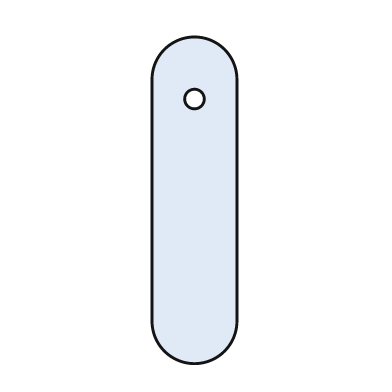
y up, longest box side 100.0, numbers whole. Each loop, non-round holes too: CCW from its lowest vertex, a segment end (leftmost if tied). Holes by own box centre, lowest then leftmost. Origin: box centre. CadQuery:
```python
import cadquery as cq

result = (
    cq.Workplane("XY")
    .moveTo(-13.0, -37.0)
    .threePointArc((0.0, -50.0), (13.0, -37.0))
    .lineTo(13.0, 37.0)
    .threePointArc((0.0, 50.0), (-13.0, 37.0))
    .close()
    .moveTo(0.0, 31.0)
    .circle(3.0)
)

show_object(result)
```